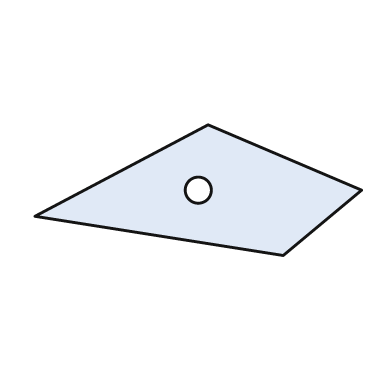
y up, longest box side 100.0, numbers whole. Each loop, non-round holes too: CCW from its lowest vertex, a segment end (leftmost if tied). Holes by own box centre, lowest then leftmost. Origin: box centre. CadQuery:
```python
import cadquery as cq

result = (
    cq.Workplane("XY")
    .moveTo(26.0, -20.0)
    .lineTo(50.0, 0.0)
    .lineTo(3.0, 20.0)
    .lineTo(-50.0, -8.0)
    .close()
    .moveTo(0.0, 0.0)
    .circle(4.0)
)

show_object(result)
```